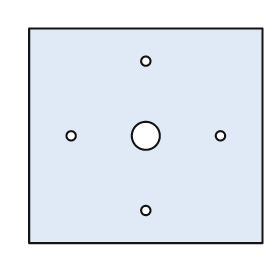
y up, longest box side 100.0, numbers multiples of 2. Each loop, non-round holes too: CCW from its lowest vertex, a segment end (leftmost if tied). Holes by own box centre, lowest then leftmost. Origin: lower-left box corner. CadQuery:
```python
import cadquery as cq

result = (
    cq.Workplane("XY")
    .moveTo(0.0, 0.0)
    .lineTo(100.0, 0.0)
    .lineTo(100.0, 92.0)
    .lineTo(0.0, 92.0)
    .close()
    .moveTo(50.0, 14.0)
    .circle(2.0)
    .moveTo(18.0, 46.0)
    .circle(2.0)
    .moveTo(50.0, 46.0)
    .circle(6.0)
    .moveTo(82.0, 46.0)
    .circle(2.0)
    .moveTo(50.0, 78.0)
    .circle(2.0)
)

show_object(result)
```